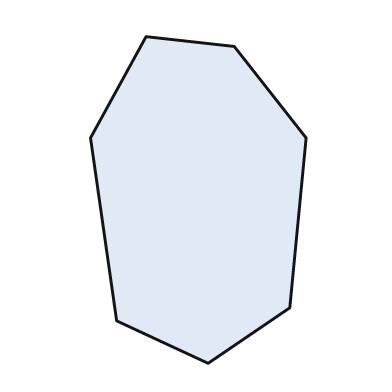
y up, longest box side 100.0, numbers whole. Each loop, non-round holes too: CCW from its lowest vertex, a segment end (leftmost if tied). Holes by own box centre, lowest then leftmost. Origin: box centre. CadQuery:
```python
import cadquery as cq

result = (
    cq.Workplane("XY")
    .moveTo(3.0, -50.0)
    .lineTo(28.0, -33.0)
    .lineTo(33.0, 19.0)
    .lineTo(11.0, 47.0)
    .lineTo(-16.0, 50.0)
    .lineTo(-33.0, 19.0)
    .lineTo(-25.0, -37.0)
    .close()
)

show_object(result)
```